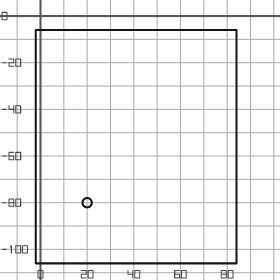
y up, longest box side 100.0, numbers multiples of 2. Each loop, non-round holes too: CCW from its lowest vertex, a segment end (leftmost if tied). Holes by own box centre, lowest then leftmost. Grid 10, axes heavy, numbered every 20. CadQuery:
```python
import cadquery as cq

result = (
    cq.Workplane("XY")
    .moveTo(-2.0, -106.0)
    .lineTo(84.0, -106.0)
    .lineTo(84.0, -6.0)
    .lineTo(-2.0, -6.0)
    .close()
    .moveTo(20.0, -80.0)
    .circle(2.0)
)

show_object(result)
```